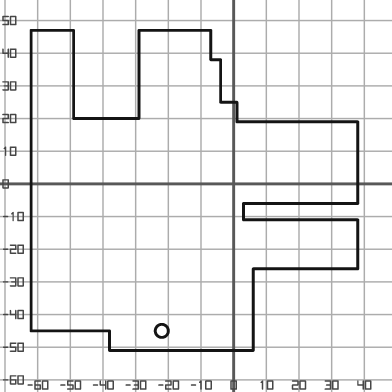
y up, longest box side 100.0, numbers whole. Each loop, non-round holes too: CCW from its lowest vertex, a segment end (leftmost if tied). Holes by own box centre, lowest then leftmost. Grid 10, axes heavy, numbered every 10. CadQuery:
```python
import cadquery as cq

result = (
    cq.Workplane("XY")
    .moveTo(-38.0, -51.0)
    .lineTo(6.0, -51.0)
    .lineTo(6.0, -26.0)
    .lineTo(38.0, -26.0)
    .lineTo(38.0, -11.0)
    .lineTo(3.0, -11.0)
    .lineTo(3.0, -6.0)
    .lineTo(38.0, -6.0)
    .lineTo(38.0, 19.0)
    .lineTo(1.0, 19.0)
    .lineTo(1.0, 25.0)
    .lineTo(-4.0, 25.0)
    .lineTo(-4.0, 38.0)
    .lineTo(-7.0, 38.0)
    .lineTo(-7.0, 47.0)
    .lineTo(-29.0, 47.0)
    .lineTo(-29.0, 20.0)
    .lineTo(-49.0, 20.0)
    .lineTo(-49.0, 47.0)
    .lineTo(-62.0, 47.0)
    .lineTo(-62.0, -45.0)
    .lineTo(-38.0, -45.0)
    .close()
    .moveTo(-22.0, -45.0)
    .circle(2.0)
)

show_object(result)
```